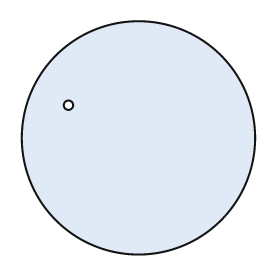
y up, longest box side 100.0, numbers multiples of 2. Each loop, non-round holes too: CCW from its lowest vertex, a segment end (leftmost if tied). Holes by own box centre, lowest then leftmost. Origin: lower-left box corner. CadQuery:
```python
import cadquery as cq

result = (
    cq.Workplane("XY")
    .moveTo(50.0, 50.0)
    .circle(50.0)
    .moveTo(20.0, 64.0)
    .circle(2.0)
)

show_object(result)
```